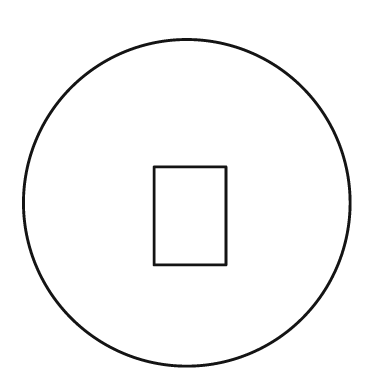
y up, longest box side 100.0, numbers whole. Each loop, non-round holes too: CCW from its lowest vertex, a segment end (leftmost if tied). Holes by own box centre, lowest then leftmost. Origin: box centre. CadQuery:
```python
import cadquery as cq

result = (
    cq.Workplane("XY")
    .moveTo(0.0, 0.0)
    .circle(50.0)
    .moveTo(-10.0, -19.0)
    .lineTo(12.0, -19.0)
    .lineTo(12.0, 11.0)
    .lineTo(-10.0, 11.0)
    .close()
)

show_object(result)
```